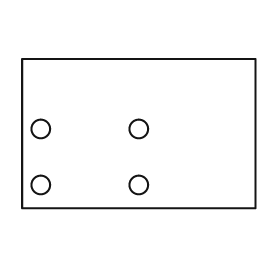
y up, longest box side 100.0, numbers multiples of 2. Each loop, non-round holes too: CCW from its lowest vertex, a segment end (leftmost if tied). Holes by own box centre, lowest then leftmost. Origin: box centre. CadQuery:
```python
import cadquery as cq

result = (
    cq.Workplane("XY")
    .moveTo(-50.0, -32.0)
    .lineTo(50.0, -32.0)
    .lineTo(50.0, 32.0)
    .lineTo(-50.0, 32.0)
    .close()
    .moveTo(-42.0, -22.0)
    .circle(4.0)
    .moveTo(0.0, -22.0)
    .circle(4.0)
    .moveTo(-42.0, 2.0)
    .circle(4.0)
    .moveTo(0.0, 2.0)
    .circle(4.0)
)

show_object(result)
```